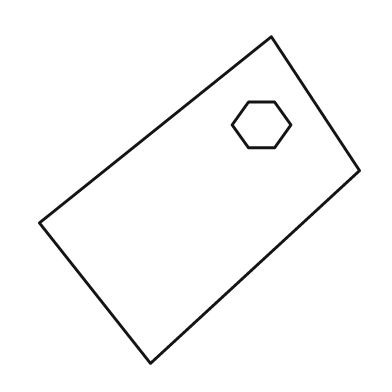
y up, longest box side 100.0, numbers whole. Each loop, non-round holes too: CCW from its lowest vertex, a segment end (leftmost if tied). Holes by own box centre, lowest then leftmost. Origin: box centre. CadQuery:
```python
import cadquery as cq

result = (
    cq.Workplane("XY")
    .moveTo(-15.0, -50.0)
    .lineTo(49.0, 9.0)
    .lineTo(22.0, 50.0)
    .lineTo(-49.0, -7.0)
    .close()
    .moveTo(15.0, 16.0)
    .lineTo(23.0, 16.0)
    .lineTo(28.0, 23.0)
    .lineTo(23.0, 30.0)
    .lineTo(15.0, 30.0)
    .lineTo(10.0, 23.0)
    .close()
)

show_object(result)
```